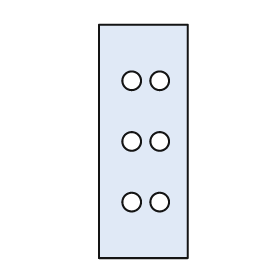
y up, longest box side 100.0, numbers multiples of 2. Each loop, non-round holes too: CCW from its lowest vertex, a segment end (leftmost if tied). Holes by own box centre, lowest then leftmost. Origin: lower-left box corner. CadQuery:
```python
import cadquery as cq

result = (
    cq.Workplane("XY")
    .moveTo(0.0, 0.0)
    .lineTo(38.0, 0.0)
    .lineTo(38.0, 100.0)
    .lineTo(0.0, 100.0)
    .close()
    .moveTo(14.0, 24.0)
    .circle(4.0)
    .moveTo(26.0, 24.0)
    .circle(4.0)
    .moveTo(14.0, 50.0)
    .circle(4.0)
    .moveTo(26.0, 50.0)
    .circle(4.0)
    .moveTo(14.0, 76.0)
    .circle(4.0)
    .moveTo(26.0, 76.0)
    .circle(4.0)
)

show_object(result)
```